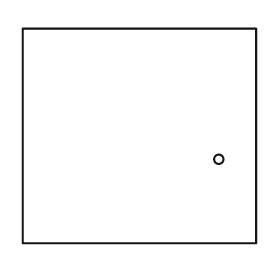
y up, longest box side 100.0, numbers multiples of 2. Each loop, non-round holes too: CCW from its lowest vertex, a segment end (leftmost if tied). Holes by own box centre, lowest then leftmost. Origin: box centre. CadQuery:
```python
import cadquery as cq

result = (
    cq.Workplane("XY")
    .moveTo(-50.0, -46.0)
    .lineTo(50.0, -46.0)
    .lineTo(50.0, 46.0)
    .lineTo(-50.0, 46.0)
    .close()
    .moveTo(34.0, -10.0)
    .circle(2.0)
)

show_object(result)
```